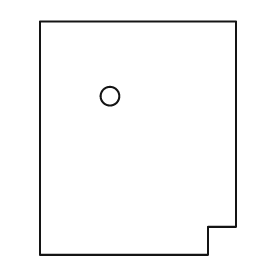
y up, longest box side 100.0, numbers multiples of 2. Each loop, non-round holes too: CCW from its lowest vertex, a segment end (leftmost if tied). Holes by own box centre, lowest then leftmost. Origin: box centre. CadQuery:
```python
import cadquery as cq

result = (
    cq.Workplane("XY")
    .moveTo(-42.0, -50.0)
    .lineTo(30.0, -50.0)
    .lineTo(30.0, -38.0)
    .lineTo(42.0, -38.0)
    .lineTo(42.0, 50.0)
    .lineTo(-42.0, 50.0)
    .close()
    .moveTo(-12.0, 18.0)
    .circle(4.0)
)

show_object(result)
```